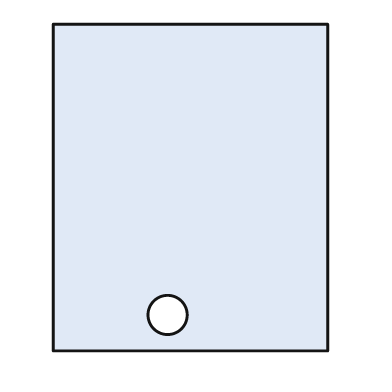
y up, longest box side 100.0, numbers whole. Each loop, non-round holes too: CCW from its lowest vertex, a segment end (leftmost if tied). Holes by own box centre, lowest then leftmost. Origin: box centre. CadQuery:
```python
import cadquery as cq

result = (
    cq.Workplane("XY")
    .moveTo(-42.0, -50.0)
    .lineTo(42.0, -50.0)
    .lineTo(42.0, 50.0)
    .lineTo(-42.0, 50.0)
    .close()
    .moveTo(-7.0, -39.0)
    .circle(6.0)
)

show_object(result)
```